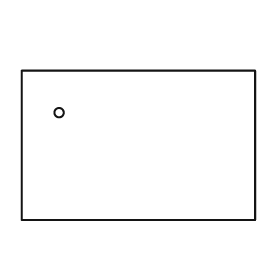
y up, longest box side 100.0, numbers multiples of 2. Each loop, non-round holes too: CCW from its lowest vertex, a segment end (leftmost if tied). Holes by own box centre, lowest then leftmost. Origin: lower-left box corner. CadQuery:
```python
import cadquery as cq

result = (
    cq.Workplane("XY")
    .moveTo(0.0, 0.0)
    .lineTo(100.0, 0.0)
    .lineTo(100.0, 64.0)
    .lineTo(0.0, 64.0)
    .close()
    .moveTo(16.0, 46.0)
    .circle(2.0)
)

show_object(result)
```